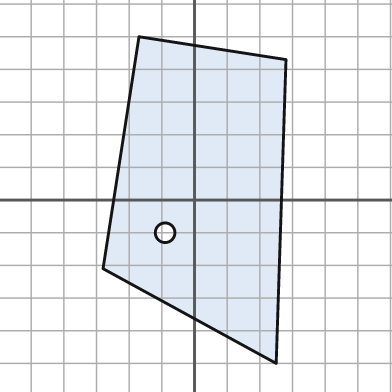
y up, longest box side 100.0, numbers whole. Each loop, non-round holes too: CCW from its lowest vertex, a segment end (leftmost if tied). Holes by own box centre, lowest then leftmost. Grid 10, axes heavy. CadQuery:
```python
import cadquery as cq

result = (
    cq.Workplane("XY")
    .moveTo(25.0, -50.0)
    .lineTo(28.0, 43.0)
    .lineTo(-17.0, 50.0)
    .lineTo(-28.0, -21.0)
    .close()
    .moveTo(-9.0, -10.0)
    .circle(3.0)
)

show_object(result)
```